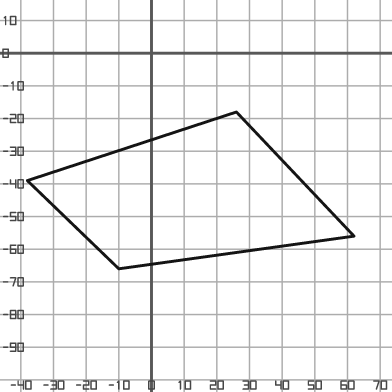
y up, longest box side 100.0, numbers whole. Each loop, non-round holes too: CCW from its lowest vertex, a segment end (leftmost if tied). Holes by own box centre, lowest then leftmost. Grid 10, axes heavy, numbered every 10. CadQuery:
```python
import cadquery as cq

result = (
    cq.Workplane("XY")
    .moveTo(-10.0, -66.0)
    .lineTo(62.0, -56.0)
    .lineTo(26.0, -18.0)
    .lineTo(-38.0, -39.0)
    .close()
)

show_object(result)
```